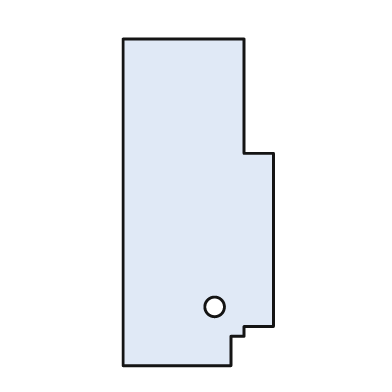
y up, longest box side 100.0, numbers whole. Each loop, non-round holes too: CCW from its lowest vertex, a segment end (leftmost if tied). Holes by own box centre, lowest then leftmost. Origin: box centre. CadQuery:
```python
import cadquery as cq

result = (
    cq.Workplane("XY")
    .moveTo(-23.0, -50.0)
    .lineTo(10.0, -50.0)
    .lineTo(10.0, -41.0)
    .lineTo(14.0, -41.0)
    .lineTo(14.0, -38.0)
    .lineTo(23.0, -38.0)
    .lineTo(23.0, 15.0)
    .lineTo(14.0, 15.0)
    .lineTo(14.0, 50.0)
    .lineTo(-23.0, 50.0)
    .close()
    .moveTo(5.0, -32.0)
    .circle(3.0)
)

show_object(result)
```